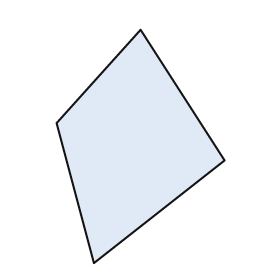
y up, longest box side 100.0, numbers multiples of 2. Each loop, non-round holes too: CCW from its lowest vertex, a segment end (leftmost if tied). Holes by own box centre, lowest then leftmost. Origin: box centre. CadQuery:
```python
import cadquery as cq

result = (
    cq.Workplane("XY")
    .moveTo(-20.0, -50.0)
    .lineTo(36.0, -6.0)
    .lineTo(0.0, 50.0)
    .lineTo(-36.0, 10.0)
    .close()
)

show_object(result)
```